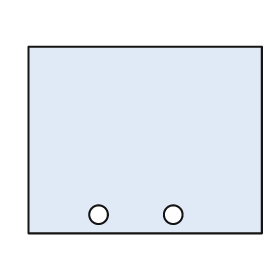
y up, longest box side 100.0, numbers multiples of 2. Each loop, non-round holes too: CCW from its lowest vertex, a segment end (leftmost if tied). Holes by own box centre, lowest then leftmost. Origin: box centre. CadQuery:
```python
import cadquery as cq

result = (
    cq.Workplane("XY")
    .moveTo(-50.0, -40.0)
    .lineTo(50.0, -40.0)
    .lineTo(50.0, 40.0)
    .lineTo(-50.0, 40.0)
    .close()
    .moveTo(-20.0, -32.0)
    .circle(4.0)
    .moveTo(12.0, -32.0)
    .circle(4.0)
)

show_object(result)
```